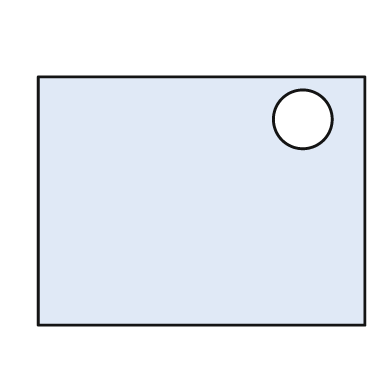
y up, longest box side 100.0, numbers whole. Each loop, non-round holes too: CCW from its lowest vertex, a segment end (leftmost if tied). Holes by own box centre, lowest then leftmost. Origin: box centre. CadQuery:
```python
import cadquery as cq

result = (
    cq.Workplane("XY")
    .moveTo(-50.0, -38.0)
    .lineTo(50.0, -38.0)
    .lineTo(50.0, 38.0)
    .lineTo(-50.0, 38.0)
    .close()
    .moveTo(31.0, 25.0)
    .circle(9.0)
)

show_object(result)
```